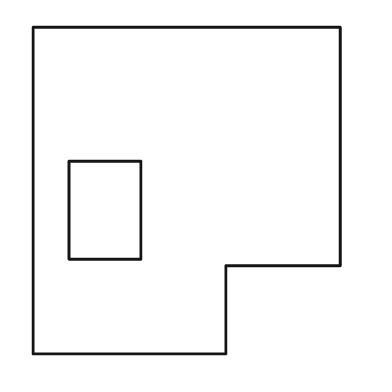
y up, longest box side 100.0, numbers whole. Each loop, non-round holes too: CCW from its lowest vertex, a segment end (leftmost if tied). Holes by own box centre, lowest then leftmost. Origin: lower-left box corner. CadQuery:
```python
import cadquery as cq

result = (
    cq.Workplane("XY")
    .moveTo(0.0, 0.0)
    .lineTo(59.0, 0.0)
    .lineTo(59.0, 27.0)
    .lineTo(94.0, 27.0)
    .lineTo(94.0, 100.0)
    .lineTo(0.0, 100.0)
    .close()
    .moveTo(11.0, 29.0)
    .lineTo(33.0, 29.0)
    .lineTo(33.0, 59.0)
    .lineTo(11.0, 59.0)
    .close()
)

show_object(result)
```